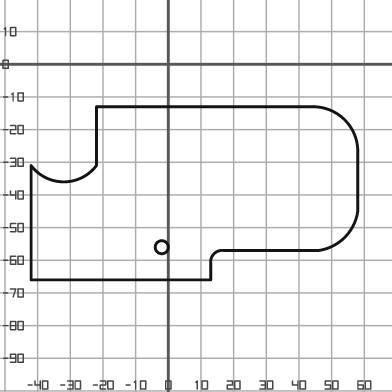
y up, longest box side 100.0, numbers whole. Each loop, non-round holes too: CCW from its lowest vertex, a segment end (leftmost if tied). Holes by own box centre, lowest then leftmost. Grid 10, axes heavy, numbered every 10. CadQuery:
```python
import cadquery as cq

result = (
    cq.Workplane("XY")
    .moveTo(-42.0, -66.0)
    .lineTo(13.0, -66.0)
    .lineTo(13.0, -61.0)
    .threePointArc((14.0, -58.0), (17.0, -57.0))
    .lineTo(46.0, -57.0)
    .threePointArc((54.0, -53.0), (58.0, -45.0))
    .lineTo(58.0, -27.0)
    .threePointArc((54.0, -17.0), (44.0, -13.0))
    .lineTo(-22.0, -13.0)
    .lineTo(-22.0, -31.0)
    .threePointArc((-32.0, -36.0), (-42.0, -31.0))
    .close()
    .moveTo(-2.0, -56.0)
    .circle(2.0)
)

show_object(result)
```